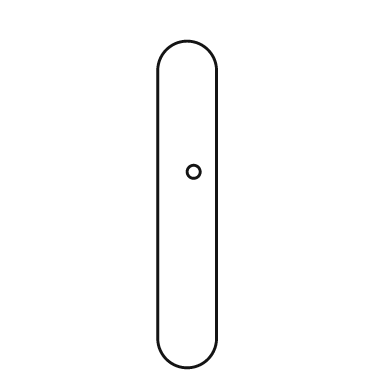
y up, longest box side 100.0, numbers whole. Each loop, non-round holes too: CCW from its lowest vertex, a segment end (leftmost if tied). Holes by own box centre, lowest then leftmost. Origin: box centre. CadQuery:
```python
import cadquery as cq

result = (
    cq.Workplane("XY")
    .moveTo(-9.0, -41.0)
    .threePointArc((0.0, -50.0), (9.0, -41.0))
    .lineTo(9.0, 41.0)
    .threePointArc((0.0, 50.0), (-9.0, 41.0))
    .close()
    .moveTo(2.0, 10.0)
    .circle(2.0)
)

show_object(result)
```